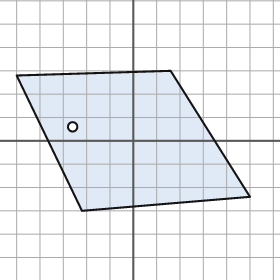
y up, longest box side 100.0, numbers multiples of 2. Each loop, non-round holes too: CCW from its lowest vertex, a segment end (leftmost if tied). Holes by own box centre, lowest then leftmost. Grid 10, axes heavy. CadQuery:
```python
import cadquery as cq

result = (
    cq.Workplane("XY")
    .moveTo(-22.0, -30.0)
    .lineTo(50.0, -24.0)
    .lineTo(16.0, 30.0)
    .lineTo(-50.0, 28.0)
    .close()
    .moveTo(-26.0, 6.0)
    .circle(2.0)
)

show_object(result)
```